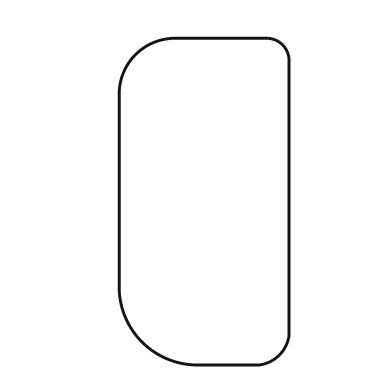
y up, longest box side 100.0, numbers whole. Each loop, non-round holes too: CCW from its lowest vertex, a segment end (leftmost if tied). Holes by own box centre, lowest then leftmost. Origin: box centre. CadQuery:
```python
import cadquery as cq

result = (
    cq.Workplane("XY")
    .moveTo(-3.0, -50.0)
    .lineTo(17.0, -50.0)
    .threePointArc((23.0, -47.0), (26.0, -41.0))
    .lineTo(26.0, 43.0)
    .threePointArc((24.0, 48.0), (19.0, 50.0))
    .lineTo(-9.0, 50.0)
    .threePointArc((-21.0, 45.0), (-26.0, 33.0))
    .lineTo(-26.0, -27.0)
    .threePointArc((-19.0, -43.0), (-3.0, -50.0))
    .close()
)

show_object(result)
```